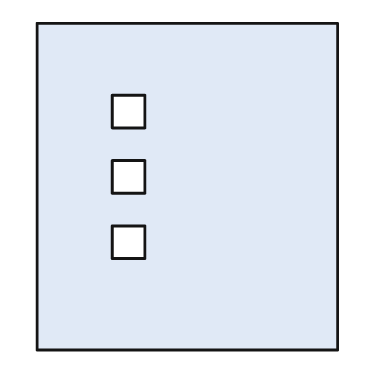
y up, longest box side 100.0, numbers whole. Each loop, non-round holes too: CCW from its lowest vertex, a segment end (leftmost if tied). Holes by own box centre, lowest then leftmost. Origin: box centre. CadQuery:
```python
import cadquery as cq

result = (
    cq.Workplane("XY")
    .moveTo(-46.0, -50.0)
    .lineTo(46.0, -50.0)
    .lineTo(46.0, 50.0)
    .lineTo(-46.0, 50.0)
    .close()
    .moveTo(-23.0, -22.0)
    .lineTo(-13.0, -22.0)
    .lineTo(-13.0, -12.0)
    .lineTo(-23.0, -12.0)
    .close()
    .moveTo(-23.0, -2.0)
    .lineTo(-13.0, -2.0)
    .lineTo(-13.0, 8.0)
    .lineTo(-23.0, 8.0)
    .close()
    .moveTo(-23.0, 18.0)
    .lineTo(-13.0, 18.0)
    .lineTo(-13.0, 28.0)
    .lineTo(-23.0, 28.0)
    .close()
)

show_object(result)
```